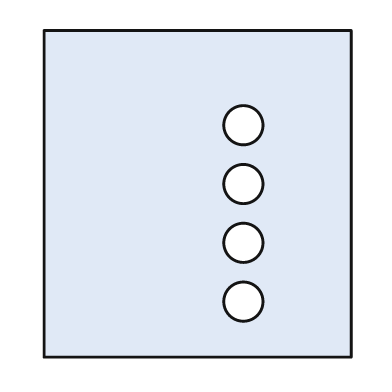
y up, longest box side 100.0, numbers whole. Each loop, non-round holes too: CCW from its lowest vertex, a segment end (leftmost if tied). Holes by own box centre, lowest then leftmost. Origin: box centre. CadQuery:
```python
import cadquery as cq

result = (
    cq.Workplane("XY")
    .moveTo(-47.0, -50.0)
    .lineTo(47.0, -50.0)
    .lineTo(47.0, 50.0)
    .lineTo(-47.0, 50.0)
    .close()
    .moveTo(14.0, -33.0)
    .circle(6.0)
    .moveTo(14.0, -15.0)
    .circle(6.0)
    .moveTo(14.0, 3.0)
    .circle(6.0)
    .moveTo(14.0, 21.0)
    .circle(6.0)
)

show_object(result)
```